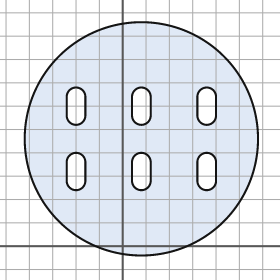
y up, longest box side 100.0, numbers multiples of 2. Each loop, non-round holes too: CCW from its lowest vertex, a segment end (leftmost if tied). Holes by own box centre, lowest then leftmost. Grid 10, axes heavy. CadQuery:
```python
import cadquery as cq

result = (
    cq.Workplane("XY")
    .moveTo(8.0, 46.0)
    .circle(50.0)
    .moveTo(-24.0, 28.0)
    .threePointArc((-20.0, 24.0), (-16.0, 28.0))
    .lineTo(-16.0, 36.0)
    .threePointArc((-20.0, 40.0), (-24.0, 36.0))
    .close()
    .moveTo(4.0, 28.0)
    .threePointArc((8.0, 24.0), (12.0, 28.0))
    .lineTo(12.0, 36.0)
    .threePointArc((8.0, 40.0), (4.0, 36.0))
    .close()
    .moveTo(32.0, 28.0)
    .threePointArc((36.0, 24.0), (40.0, 28.0))
    .lineTo(40.0, 36.0)
    .threePointArc((36.0, 40.0), (32.0, 36.0))
    .close()
    .moveTo(-24.0, 56.0)
    .threePointArc((-20.0, 52.0), (-16.0, 56.0))
    .lineTo(-16.0, 64.0)
    .threePointArc((-20.0, 68.0), (-24.0, 64.0))
    .close()
    .moveTo(4.0, 56.0)
    .threePointArc((8.0, 52.0), (12.0, 56.0))
    .lineTo(12.0, 64.0)
    .threePointArc((8.0, 68.0), (4.0, 64.0))
    .close()
    .moveTo(32.0, 56.0)
    .threePointArc((36.0, 52.0), (40.0, 56.0))
    .lineTo(40.0, 64.0)
    .threePointArc((36.0, 68.0), (32.0, 64.0))
    .close()
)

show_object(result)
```